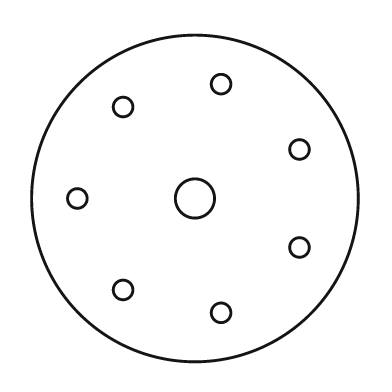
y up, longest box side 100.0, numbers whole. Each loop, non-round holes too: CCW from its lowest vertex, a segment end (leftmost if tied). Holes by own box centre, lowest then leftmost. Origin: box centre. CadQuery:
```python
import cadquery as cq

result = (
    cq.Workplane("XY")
    .moveTo(0.0, 0.0)
    .circle(50.0)
    .moveTo(8.0, -35.0)
    .circle(3.0)
    .moveTo(-22.0, -28.0)
    .circle(3.0)
    .moveTo(32.0, -15.0)
    .circle(3.0)
    .moveTo(-36.0, 0.0)
    .circle(3.0)
    .moveTo(0.0, 0.0)
    .circle(6.0)
    .moveTo(32.0, 15.0)
    .circle(3.0)
    .moveTo(-22.0, 28.0)
    .circle(3.0)
    .moveTo(8.0, 35.0)
    .circle(3.0)
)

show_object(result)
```